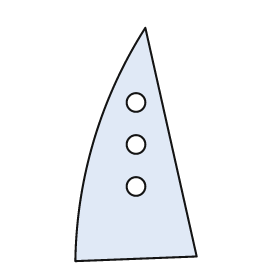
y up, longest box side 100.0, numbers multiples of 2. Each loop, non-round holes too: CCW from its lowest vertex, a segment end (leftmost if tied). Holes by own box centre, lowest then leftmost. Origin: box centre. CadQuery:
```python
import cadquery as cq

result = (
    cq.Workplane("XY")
    .moveTo(-26.0, -50.0)
    .lineTo(26.0, -48.0)
    .lineTo(4.0, 50.0)
    .threePointArc((-18.0, 2.0), (-26.0, -50.0))
    .close()
    .moveTo(0.0, -18.0)
    .circle(4.0)
    .moveTo(0.0, 0.0)
    .circle(4.0)
    .moveTo(0.0, 18.0)
    .circle(4.0)
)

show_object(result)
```